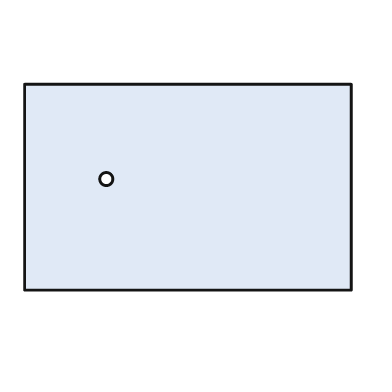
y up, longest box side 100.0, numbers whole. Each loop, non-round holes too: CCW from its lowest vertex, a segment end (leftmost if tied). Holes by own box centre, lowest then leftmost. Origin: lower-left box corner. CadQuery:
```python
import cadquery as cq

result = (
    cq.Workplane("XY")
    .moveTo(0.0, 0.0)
    .lineTo(100.0, 0.0)
    .lineTo(100.0, 63.0)
    .lineTo(0.0, 63.0)
    .close()
    .moveTo(25.0, 34.0)
    .circle(2.0)
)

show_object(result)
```